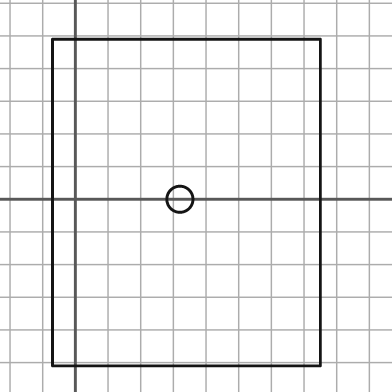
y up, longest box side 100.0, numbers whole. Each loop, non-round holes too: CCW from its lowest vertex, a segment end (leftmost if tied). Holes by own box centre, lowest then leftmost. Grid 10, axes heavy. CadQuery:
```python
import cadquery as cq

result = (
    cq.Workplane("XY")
    .moveTo(-7.0, -51.0)
    .lineTo(75.0, -51.0)
    .lineTo(75.0, 49.0)
    .lineTo(-7.0, 49.0)
    .close()
    .moveTo(32.0, 0.0)
    .circle(4.0)
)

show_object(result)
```